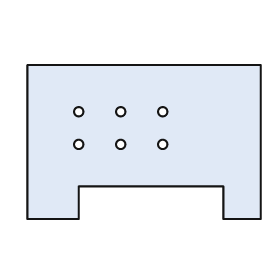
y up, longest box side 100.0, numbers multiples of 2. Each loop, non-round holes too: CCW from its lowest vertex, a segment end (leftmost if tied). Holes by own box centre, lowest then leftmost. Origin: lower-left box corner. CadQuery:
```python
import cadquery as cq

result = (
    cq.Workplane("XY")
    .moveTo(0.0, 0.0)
    .lineTo(22.0, 0.0)
    .lineTo(22.0, 14.0)
    .lineTo(84.0, 14.0)
    .lineTo(84.0, 0.0)
    .lineTo(100.0, 0.0)
    .lineTo(100.0, 66.0)
    .lineTo(0.0, 66.0)
    .close()
    .moveTo(22.0, 32.0)
    .circle(2.0)
    .moveTo(40.0, 32.0)
    .circle(2.0)
    .moveTo(58.0, 32.0)
    .circle(2.0)
    .moveTo(22.0, 46.0)
    .circle(2.0)
    .moveTo(40.0, 46.0)
    .circle(2.0)
    .moveTo(58.0, 46.0)
    .circle(2.0)
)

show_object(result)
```